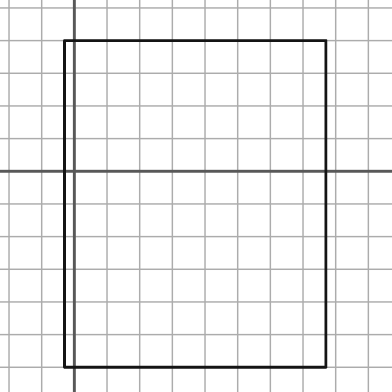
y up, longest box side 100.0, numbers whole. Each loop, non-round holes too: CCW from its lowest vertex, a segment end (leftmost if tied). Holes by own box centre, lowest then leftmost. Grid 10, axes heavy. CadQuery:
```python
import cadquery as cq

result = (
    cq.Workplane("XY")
    .moveTo(-3.0, -60.0)
    .lineTo(77.0, -60.0)
    .lineTo(77.0, 40.0)
    .lineTo(-3.0, 40.0)
    .close()
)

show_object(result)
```